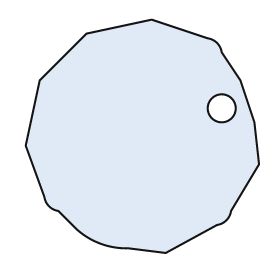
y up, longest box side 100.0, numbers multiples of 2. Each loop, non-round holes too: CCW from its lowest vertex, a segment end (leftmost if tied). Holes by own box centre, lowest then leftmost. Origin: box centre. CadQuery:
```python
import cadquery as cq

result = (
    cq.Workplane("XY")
    .moveTo(10.0, -50.0)
    .lineTo(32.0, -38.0)
    .threePointArc((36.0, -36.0), (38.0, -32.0))
    .lineTo(50.0, -12.0)
    .lineTo(48.0, 6.0)
    .lineTo(42.0, 24.0)
    .lineTo(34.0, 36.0)
    .threePointArc((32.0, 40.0), (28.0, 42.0))
    .lineTo(4.0, 50.0)
    .lineTo(-24.0, 44.0)
    .lineTo(-44.0, 24.0)
    .lineTo(-50.0, -4.0)
    .lineTo(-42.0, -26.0)
    .threePointArc((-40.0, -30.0), (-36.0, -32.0))
    .lineTo(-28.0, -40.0)
    .threePointArc((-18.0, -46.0), (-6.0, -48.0))
    .close()
    .moveTo(34.0, 12.0)
    .circle(6.0)
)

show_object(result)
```